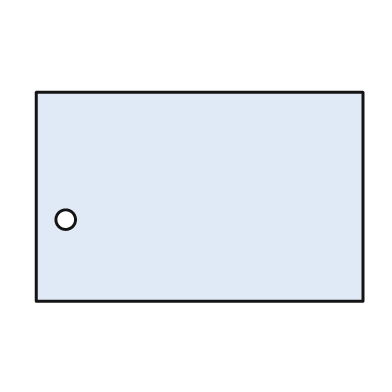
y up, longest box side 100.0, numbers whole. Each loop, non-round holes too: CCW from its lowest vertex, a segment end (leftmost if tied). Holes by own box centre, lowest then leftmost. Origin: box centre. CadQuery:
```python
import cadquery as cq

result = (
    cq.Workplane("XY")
    .moveTo(-50.0, -32.0)
    .lineTo(50.0, -32.0)
    .lineTo(50.0, 32.0)
    .lineTo(-50.0, 32.0)
    .close()
    .moveTo(-41.0, -7.0)
    .circle(3.0)
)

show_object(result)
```